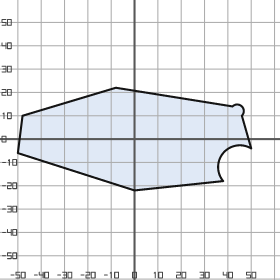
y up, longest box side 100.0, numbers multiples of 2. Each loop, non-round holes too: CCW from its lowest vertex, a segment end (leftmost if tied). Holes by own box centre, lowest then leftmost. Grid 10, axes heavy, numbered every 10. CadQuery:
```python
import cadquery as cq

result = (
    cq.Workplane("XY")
    .moveTo(0.0, -22.0)
    .lineTo(38.0, -18.0)
    .threePointArc((38.0, -6.0), (50.0, -4.0))
    .lineTo(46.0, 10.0)
    .threePointArc((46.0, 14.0), (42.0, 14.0))
    .lineTo(-8.0, 22.0)
    .lineTo(-48.0, 10.0)
    .lineTo(-50.0, -6.0)
    .close()
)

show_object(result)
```